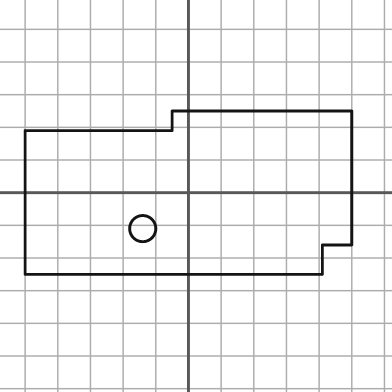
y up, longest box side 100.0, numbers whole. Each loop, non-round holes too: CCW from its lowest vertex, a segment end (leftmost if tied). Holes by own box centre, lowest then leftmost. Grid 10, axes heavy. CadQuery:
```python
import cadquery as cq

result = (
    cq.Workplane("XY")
    .moveTo(-50.0, -25.0)
    .lineTo(41.0, -25.0)
    .lineTo(41.0, -16.0)
    .lineTo(50.0, -16.0)
    .lineTo(50.0, 25.0)
    .lineTo(-5.0, 25.0)
    .lineTo(-5.0, 19.0)
    .lineTo(-50.0, 19.0)
    .close()
    .moveTo(-14.0, -11.0)
    .circle(4.0)
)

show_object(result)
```